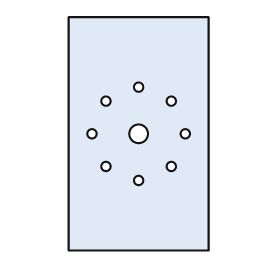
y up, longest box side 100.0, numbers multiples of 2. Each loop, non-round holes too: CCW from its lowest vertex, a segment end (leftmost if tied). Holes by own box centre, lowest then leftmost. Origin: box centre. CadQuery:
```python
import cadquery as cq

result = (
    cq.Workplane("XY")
    .moveTo(-30.0, -50.0)
    .lineTo(30.0, -50.0)
    .lineTo(30.0, 50.0)
    .lineTo(-30.0, 50.0)
    .close()
    .moveTo(0.0, -20.0)
    .circle(2.0)
    .moveTo(-14.0, -14.0)
    .circle(2.0)
    .moveTo(14.0, -14.0)
    .circle(2.0)
    .moveTo(-20.0, 0.0)
    .circle(2.0)
    .moveTo(0.0, 0.0)
    .circle(4.0)
    .moveTo(20.0, 0.0)
    .circle(2.0)
    .moveTo(-14.0, 14.0)
    .circle(2.0)
    .moveTo(14.0, 14.0)
    .circle(2.0)
    .moveTo(0.0, 20.0)
    .circle(2.0)
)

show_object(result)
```